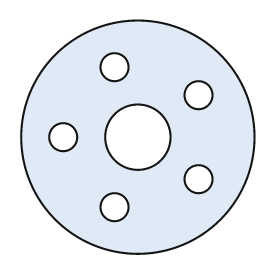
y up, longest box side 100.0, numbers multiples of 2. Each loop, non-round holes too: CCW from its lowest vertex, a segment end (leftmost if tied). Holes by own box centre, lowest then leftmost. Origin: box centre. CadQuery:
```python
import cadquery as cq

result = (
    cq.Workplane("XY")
    .moveTo(0.0, 0.0)
    .circle(50.0)
    .moveTo(-10.0, -30.0)
    .circle(6.0)
    .moveTo(26.0, -18.0)
    .circle(6.0)
    .moveTo(-32.0, 0.0)
    .circle(6.0)
    .moveTo(0.0, 0.0)
    .circle(14.0)
    .moveTo(26.0, 18.0)
    .circle(6.0)
    .moveTo(-10.0, 30.0)
    .circle(6.0)
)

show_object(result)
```